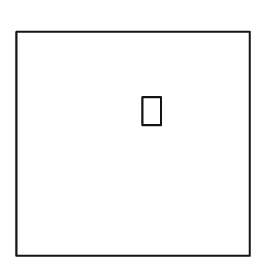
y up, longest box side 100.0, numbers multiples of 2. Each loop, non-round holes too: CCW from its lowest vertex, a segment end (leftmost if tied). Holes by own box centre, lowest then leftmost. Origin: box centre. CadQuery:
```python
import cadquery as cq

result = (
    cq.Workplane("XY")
    .moveTo(-50.0, -48.0)
    .lineTo(50.0, -48.0)
    .lineTo(50.0, 48.0)
    .lineTo(-50.0, 48.0)
    .close()
    .moveTo(4.0, 8.0)
    .lineTo(12.0, 8.0)
    .lineTo(12.0, 20.0)
    .lineTo(4.0, 20.0)
    .close()
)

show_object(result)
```